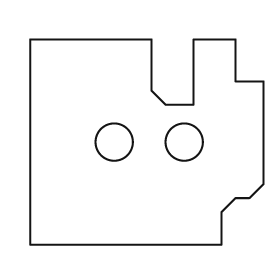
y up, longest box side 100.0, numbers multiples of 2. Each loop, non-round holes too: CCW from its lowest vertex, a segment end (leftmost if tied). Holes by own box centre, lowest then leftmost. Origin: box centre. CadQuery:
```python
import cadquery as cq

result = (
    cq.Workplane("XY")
    .moveTo(-50.0, -44.0)
    .lineTo(32.0, -44.0)
    .lineTo(32.0, -30.0)
    .lineTo(38.0, -24.0)
    .lineTo(44.0, -24.0)
    .lineTo(50.0, -18.0)
    .lineTo(50.0, 26.0)
    .lineTo(38.0, 26.0)
    .lineTo(38.0, 44.0)
    .lineTo(20.0, 44.0)
    .lineTo(20.0, 16.0)
    .lineTo(8.0, 16.0)
    .lineTo(2.0, 22.0)
    .lineTo(2.0, 44.0)
    .lineTo(-50.0, 44.0)
    .close()
    .moveTo(-14.0, 0.0)
    .circle(8.0)
    .moveTo(16.0, 0.0)
    .circle(8.0)
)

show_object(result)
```